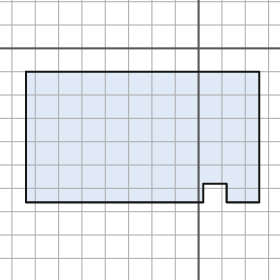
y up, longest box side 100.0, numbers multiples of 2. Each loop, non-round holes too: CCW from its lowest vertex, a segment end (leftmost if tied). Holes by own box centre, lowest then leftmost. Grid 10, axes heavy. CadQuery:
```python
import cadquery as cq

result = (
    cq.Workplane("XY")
    .moveTo(-74.0, -66.0)
    .lineTo(2.0, -66.0)
    .lineTo(2.0, -58.0)
    .lineTo(12.0, -58.0)
    .lineTo(12.0, -66.0)
    .lineTo(26.0, -66.0)
    .lineTo(26.0, -10.0)
    .lineTo(-74.0, -10.0)
    .close()
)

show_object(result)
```